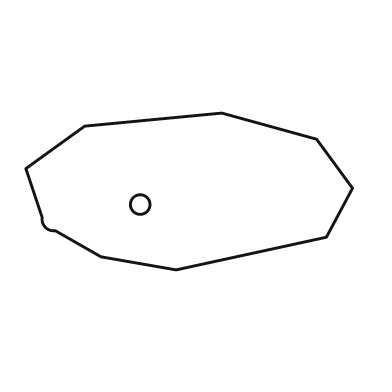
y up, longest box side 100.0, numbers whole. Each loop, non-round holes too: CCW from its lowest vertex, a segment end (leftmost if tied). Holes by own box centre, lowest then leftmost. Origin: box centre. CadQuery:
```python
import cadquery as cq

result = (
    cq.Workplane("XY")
    .moveTo(-4.0, -24.0)
    .lineTo(42.0, -14.0)
    .lineTo(50.0, 1.0)
    .lineTo(39.0, 16.0)
    .lineTo(10.0, 24.0)
    .lineTo(-32.0, 20.0)
    .lineTo(-50.0, 7.0)
    .lineTo(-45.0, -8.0)
    .threePointArc((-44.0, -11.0), (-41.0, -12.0))
    .lineTo(-27.0, -20.0)
    .close()
    .moveTo(-15.0, -4.0)
    .circle(3.0)
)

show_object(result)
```